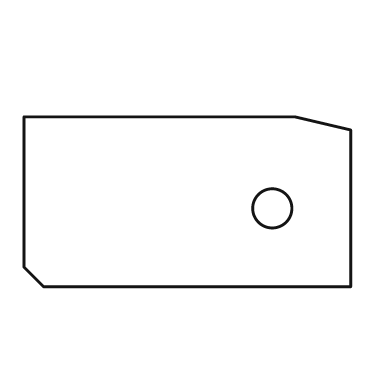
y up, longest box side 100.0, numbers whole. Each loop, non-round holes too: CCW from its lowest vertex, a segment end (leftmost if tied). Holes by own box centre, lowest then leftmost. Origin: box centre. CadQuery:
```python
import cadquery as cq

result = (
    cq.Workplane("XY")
    .moveTo(-44.0, -26.0)
    .lineTo(50.0, -26.0)
    .lineTo(50.0, 22.0)
    .lineTo(33.0, 26.0)
    .lineTo(-50.0, 26.0)
    .lineTo(-50.0, -20.0)
    .close()
    .moveTo(26.0, -2.0)
    .circle(6.0)
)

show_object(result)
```